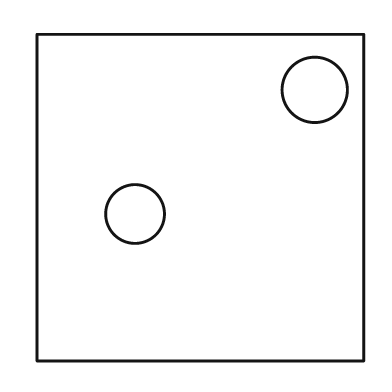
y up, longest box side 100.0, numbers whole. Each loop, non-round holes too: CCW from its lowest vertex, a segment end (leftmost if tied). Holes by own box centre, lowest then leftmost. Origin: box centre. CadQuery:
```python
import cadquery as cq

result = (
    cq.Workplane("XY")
    .moveTo(-50.0, -50.0)
    .lineTo(50.0, -50.0)
    .lineTo(50.0, 50.0)
    .lineTo(-50.0, 50.0)
    .close()
    .moveTo(-20.0, -5.0)
    .circle(9.0)
    .moveTo(35.0, 33.0)
    .circle(10.0)
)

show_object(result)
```